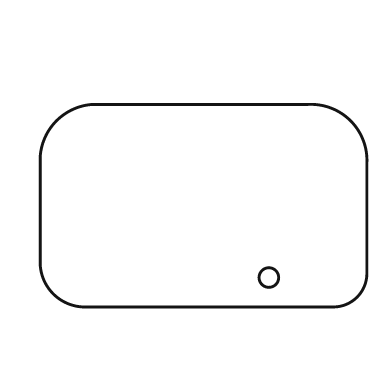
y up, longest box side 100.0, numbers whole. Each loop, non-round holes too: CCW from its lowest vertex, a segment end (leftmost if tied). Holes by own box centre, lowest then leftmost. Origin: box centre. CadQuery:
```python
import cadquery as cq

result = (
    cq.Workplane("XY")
    .moveTo(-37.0, -31.0)
    .lineTo(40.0, -31.0)
    .threePointArc((47.0, -28.0), (50.0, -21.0))
    .lineTo(50.0, 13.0)
    .threePointArc((45.0, 26.0), (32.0, 31.0))
    .lineTo(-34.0, 31.0)
    .threePointArc((-45.0, 26.0), (-50.0, 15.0))
    .lineTo(-50.0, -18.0)
    .threePointArc((-46.0, -27.0), (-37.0, -31.0))
    .close()
    .moveTo(20.0, -22.0)
    .circle(3.0)
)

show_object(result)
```